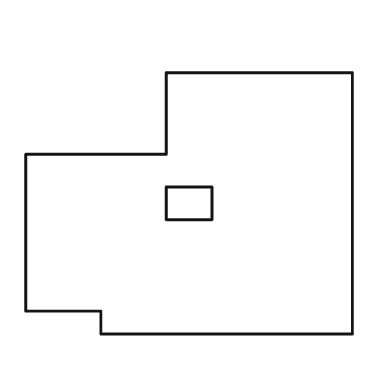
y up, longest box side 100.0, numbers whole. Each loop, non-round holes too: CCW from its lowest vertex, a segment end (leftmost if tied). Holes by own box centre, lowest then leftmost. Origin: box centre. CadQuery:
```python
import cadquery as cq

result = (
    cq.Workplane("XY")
    .moveTo(-27.0, -40.0)
    .lineTo(50.0, -40.0)
    .lineTo(50.0, 40.0)
    .lineTo(-7.0, 40.0)
    .lineTo(-7.0, 15.0)
    .lineTo(-50.0, 15.0)
    .lineTo(-50.0, -33.0)
    .lineTo(-27.0, -33.0)
    .close()
    .moveTo(-7.0, -5.0)
    .lineTo(7.0, -5.0)
    .lineTo(7.0, 5.0)
    .lineTo(-7.0, 5.0)
    .close()
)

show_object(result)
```